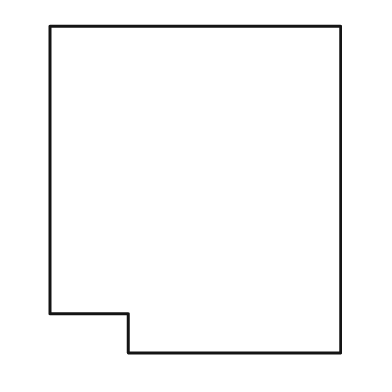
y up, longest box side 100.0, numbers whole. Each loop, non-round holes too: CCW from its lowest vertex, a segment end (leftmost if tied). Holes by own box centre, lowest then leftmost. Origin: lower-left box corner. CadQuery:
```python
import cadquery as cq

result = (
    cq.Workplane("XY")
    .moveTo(24.0, 0.0)
    .lineTo(89.0, 0.0)
    .lineTo(89.0, 100.0)
    .lineTo(0.0, 100.0)
    .lineTo(0.0, 12.0)
    .lineTo(24.0, 12.0)
    .close()
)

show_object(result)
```